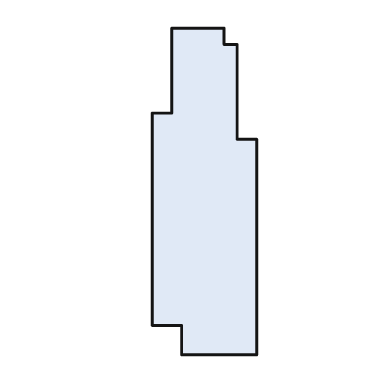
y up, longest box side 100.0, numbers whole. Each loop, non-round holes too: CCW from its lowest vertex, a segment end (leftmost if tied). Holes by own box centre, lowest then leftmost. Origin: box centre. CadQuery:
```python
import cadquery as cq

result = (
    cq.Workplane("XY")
    .moveTo(-7.0, -50.0)
    .lineTo(16.0, -50.0)
    .lineTo(16.0, 16.0)
    .lineTo(10.0, 16.0)
    .lineTo(10.0, 45.0)
    .lineTo(6.0, 45.0)
    .lineTo(6.0, 50.0)
    .lineTo(-10.0, 50.0)
    .lineTo(-10.0, 24.0)
    .lineTo(-16.0, 24.0)
    .lineTo(-16.0, -41.0)
    .lineTo(-7.0, -41.0)
    .close()
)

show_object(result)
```